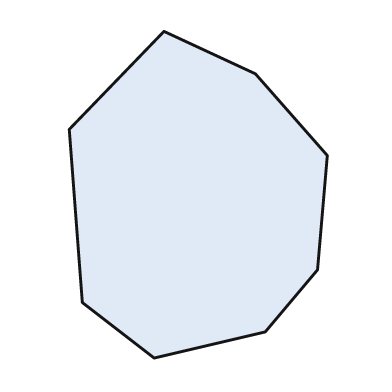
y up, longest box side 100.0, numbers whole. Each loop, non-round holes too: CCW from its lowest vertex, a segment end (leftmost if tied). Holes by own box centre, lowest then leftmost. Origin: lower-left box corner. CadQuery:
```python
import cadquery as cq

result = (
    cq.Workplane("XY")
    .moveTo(26.0, 0.0)
    .lineTo(60.0, 8.0)
    .lineTo(76.0, 27.0)
    .lineTo(79.0, 62.0)
    .lineTo(57.0, 87.0)
    .lineTo(29.0, 100.0)
    .lineTo(0.0, 70.0)
    .lineTo(4.0, 17.0)
    .close()
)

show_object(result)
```